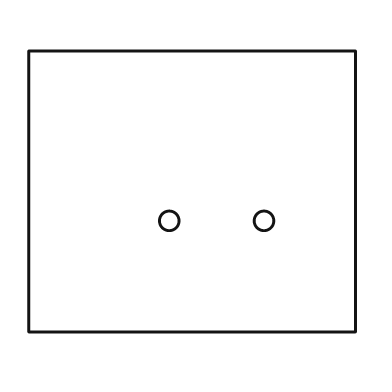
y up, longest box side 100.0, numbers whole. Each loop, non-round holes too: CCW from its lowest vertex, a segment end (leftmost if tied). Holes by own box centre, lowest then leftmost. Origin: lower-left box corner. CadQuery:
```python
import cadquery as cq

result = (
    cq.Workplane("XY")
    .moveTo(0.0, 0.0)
    .lineTo(100.0, 0.0)
    .lineTo(100.0, 86.0)
    .lineTo(0.0, 86.0)
    .close()
    .moveTo(43.0, 34.0)
    .circle(3.0)
    .moveTo(72.0, 34.0)
    .circle(3.0)
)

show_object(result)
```